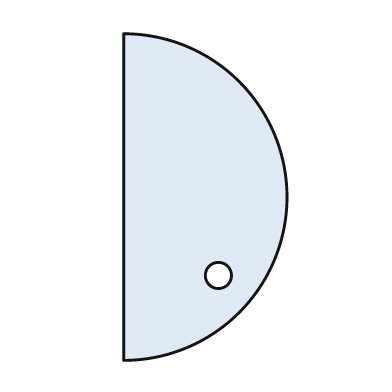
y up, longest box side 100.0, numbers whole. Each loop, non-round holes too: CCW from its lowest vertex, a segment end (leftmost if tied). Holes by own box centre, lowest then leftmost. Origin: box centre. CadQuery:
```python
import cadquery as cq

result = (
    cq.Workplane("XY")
    .moveTo(-25.0, -50.0)
    .threePointArc((25.0, 0.0), (-25.0, 50.0))
    .close()
    .moveTo(4.0, -24.0)
    .circle(4.0)
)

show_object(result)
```